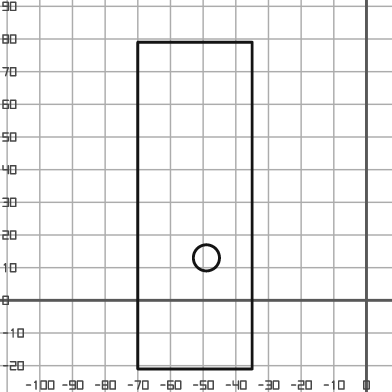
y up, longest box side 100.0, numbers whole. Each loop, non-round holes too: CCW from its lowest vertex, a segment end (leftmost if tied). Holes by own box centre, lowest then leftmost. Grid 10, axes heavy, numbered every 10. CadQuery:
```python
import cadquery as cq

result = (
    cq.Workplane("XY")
    .moveTo(-70.0, -21.0)
    .lineTo(-35.0, -21.0)
    .lineTo(-35.0, 79.0)
    .lineTo(-70.0, 79.0)
    .close()
    .moveTo(-49.0, 13.0)
    .circle(4.0)
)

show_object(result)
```